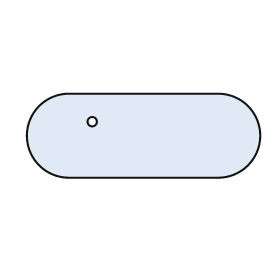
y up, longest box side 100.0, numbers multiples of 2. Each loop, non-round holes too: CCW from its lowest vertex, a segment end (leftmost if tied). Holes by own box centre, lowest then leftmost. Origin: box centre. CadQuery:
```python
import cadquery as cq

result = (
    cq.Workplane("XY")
    .moveTo(-32.0, -18.0)
    .lineTo(32.0, -18.0)
    .threePointArc((50.0, 0.0), (32.0, 18.0))
    .lineTo(-32.0, 18.0)
    .threePointArc((-50.0, 0.0), (-32.0, -18.0))
    .close()
    .moveTo(-22.0, 6.0)
    .circle(2.0)
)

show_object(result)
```